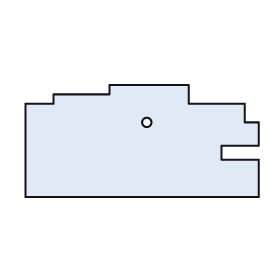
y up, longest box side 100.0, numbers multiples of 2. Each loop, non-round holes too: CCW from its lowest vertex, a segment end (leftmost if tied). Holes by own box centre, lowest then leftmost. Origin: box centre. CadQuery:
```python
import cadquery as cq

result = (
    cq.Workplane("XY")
    .moveTo(-50.0, -24.0)
    .lineTo(50.0, -24.0)
    .lineTo(50.0, -8.0)
    .lineTo(34.0, -8.0)
    .lineTo(34.0, -2.0)
    .lineTo(50.0, -2.0)
    .lineTo(50.0, 8.0)
    .lineTo(44.0, 8.0)
    .lineTo(44.0, 16.0)
    .lineTo(20.0, 16.0)
    .lineTo(20.0, 24.0)
    .lineTo(-14.0, 24.0)
    .lineTo(-14.0, 20.0)
    .lineTo(-38.0, 20.0)
    .lineTo(-38.0, 16.0)
    .lineTo(-50.0, 16.0)
    .close()
    .moveTo(2.0, 8.0)
    .circle(2.0)
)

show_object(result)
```